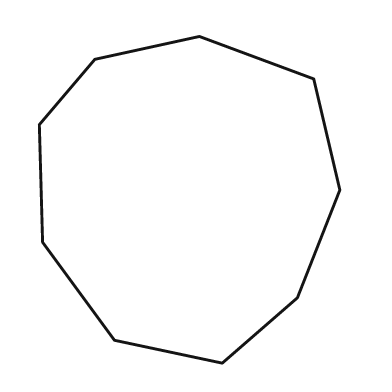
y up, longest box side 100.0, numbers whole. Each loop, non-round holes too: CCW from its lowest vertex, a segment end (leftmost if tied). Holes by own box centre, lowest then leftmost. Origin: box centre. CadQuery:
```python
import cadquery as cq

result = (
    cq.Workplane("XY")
    .moveTo(10.0, -50.0)
    .lineTo(33.0, -30.0)
    .lineTo(46.0, 3.0)
    .lineTo(38.0, 37.0)
    .lineTo(3.0, 50.0)
    .lineTo(-29.0, 43.0)
    .lineTo(-46.0, 23.0)
    .lineTo(-45.0, -13.0)
    .lineTo(-23.0, -43.0)
    .close()
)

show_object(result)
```